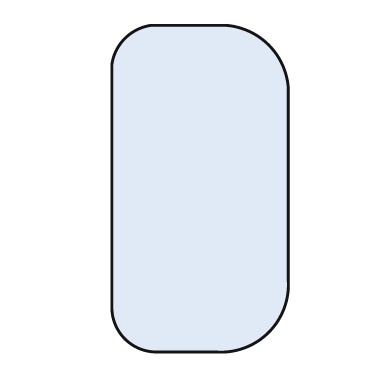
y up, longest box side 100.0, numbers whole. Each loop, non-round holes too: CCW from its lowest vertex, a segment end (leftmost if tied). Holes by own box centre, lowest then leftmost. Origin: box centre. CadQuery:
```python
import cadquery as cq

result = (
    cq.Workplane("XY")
    .moveTo(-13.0, -50.0)
    .lineTo(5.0, -50.0)
    .threePointArc((21.0, -44.0), (27.0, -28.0))
    .lineTo(27.0, 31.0)
    .threePointArc((21.0, 44.0), (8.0, 50.0))
    .lineTo(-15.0, 50.0)
    .threePointArc((-23.0, 46.0), (-27.0, 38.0))
    .lineTo(-27.0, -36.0)
    .threePointArc((-23.0, -46.0), (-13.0, -50.0))
    .close()
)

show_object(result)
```